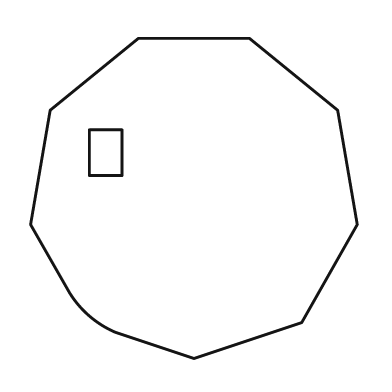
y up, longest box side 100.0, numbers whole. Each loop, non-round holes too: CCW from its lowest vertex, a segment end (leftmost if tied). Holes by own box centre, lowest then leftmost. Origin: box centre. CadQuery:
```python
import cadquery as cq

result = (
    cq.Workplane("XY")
    .moveTo(0.0, -49.0)
    .lineTo(33.0, -38.0)
    .lineTo(50.0, -8.0)
    .lineTo(44.0, 27.0)
    .lineTo(17.0, 49.0)
    .lineTo(-17.0, 49.0)
    .lineTo(-44.0, 27.0)
    .lineTo(-50.0, -8.0)
    .lineTo(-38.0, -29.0)
    .threePointArc((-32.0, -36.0), (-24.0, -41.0))
    .close()
    .moveTo(-32.0, 7.0)
    .lineTo(-22.0, 7.0)
    .lineTo(-22.0, 21.0)
    .lineTo(-32.0, 21.0)
    .close()
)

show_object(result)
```